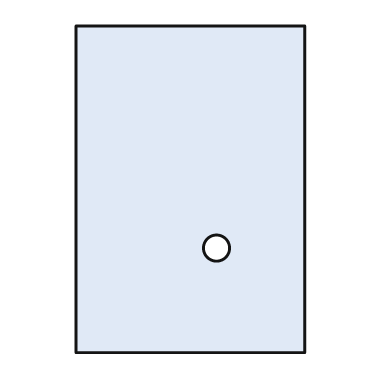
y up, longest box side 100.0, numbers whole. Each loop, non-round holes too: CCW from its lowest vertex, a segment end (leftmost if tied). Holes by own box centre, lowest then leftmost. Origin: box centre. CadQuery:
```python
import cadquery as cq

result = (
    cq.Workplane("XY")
    .moveTo(-35.0, -50.0)
    .lineTo(35.0, -50.0)
    .lineTo(35.0, 50.0)
    .lineTo(-35.0, 50.0)
    .close()
    .moveTo(8.0, -18.0)
    .circle(4.0)
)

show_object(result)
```